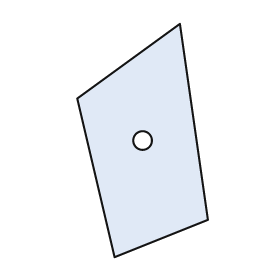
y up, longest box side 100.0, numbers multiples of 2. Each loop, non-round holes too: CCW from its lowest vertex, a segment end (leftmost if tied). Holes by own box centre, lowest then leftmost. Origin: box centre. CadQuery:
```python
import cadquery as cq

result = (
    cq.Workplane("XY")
    .moveTo(-12.0, -50.0)
    .lineTo(28.0, -34.0)
    .lineTo(16.0, 50.0)
    .lineTo(-28.0, 18.0)
    .close()
    .moveTo(0.0, 0.0)
    .circle(4.0)
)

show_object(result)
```